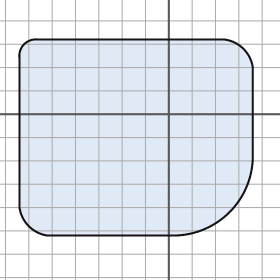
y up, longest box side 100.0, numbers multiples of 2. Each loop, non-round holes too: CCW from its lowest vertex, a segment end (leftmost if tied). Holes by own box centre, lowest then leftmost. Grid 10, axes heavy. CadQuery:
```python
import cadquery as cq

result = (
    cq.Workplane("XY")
    .moveTo(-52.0, -52.0)
    .lineTo(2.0, -52.0)
    .threePointArc((26.0, -42.0), (36.0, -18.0))
    .lineTo(36.0, 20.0)
    .threePointArc((32.0, 28.0), (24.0, 32.0))
    .lineTo(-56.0, 32.0)
    .threePointArc((-62.0, 30.0), (-64.0, 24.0))
    .lineTo(-64.0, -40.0)
    .threePointArc((-60.0, -48.0), (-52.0, -52.0))
    .close()
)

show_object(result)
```